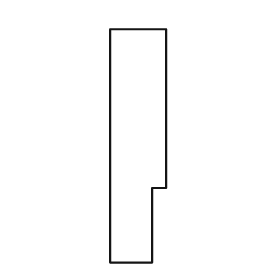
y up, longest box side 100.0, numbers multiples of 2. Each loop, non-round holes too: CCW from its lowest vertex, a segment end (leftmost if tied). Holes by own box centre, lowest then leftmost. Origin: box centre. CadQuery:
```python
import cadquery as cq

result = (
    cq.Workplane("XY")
    .moveTo(-12.0, -50.0)
    .lineTo(6.0, -50.0)
    .lineTo(6.0, -18.0)
    .lineTo(12.0, -18.0)
    .lineTo(12.0, 50.0)
    .lineTo(-12.0, 50.0)
    .close()
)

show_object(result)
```